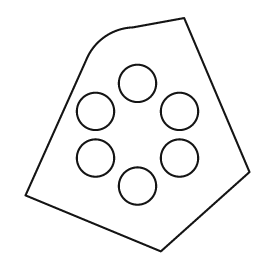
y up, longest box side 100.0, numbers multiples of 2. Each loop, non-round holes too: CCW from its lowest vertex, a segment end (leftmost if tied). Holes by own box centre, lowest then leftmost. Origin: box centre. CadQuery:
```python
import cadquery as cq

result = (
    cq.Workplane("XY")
    .moveTo(10.0, -50.0)
    .lineTo(48.0, -16.0)
    .lineTo(20.0, 50.0)
    .lineTo(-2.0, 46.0)
    .threePointArc((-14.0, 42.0), (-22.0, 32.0))
    .lineTo(-48.0, -26.0)
    .close()
    .moveTo(0.0, -22.0)
    .circle(8.0)
    .moveTo(-18.0, -10.0)
    .circle(8.0)
    .moveTo(18.0, -10.0)
    .circle(8.0)
    .moveTo(-18.0, 10.0)
    .circle(8.0)
    .moveTo(18.0, 10.0)
    .circle(8.0)
    .moveTo(0.0, 22.0)
    .circle(8.0)
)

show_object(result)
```